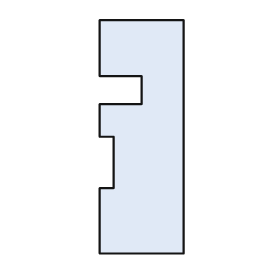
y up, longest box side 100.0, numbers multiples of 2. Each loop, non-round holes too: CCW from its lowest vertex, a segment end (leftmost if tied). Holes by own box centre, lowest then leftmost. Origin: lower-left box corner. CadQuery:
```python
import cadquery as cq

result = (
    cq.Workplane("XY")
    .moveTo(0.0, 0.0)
    .lineTo(36.0, 0.0)
    .lineTo(36.0, 100.0)
    .lineTo(0.0, 100.0)
    .lineTo(0.0, 76.0)
    .lineTo(18.0, 76.0)
    .lineTo(18.0, 64.0)
    .lineTo(0.0, 64.0)
    .lineTo(0.0, 50.0)
    .lineTo(6.0, 50.0)
    .lineTo(6.0, 28.0)
    .lineTo(0.0, 28.0)
    .close()
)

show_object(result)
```